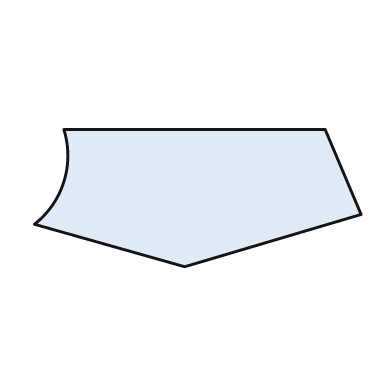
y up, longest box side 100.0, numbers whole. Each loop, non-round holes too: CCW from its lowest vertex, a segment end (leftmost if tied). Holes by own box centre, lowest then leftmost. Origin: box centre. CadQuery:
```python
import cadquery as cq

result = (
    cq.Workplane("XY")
    .moveTo(-4.0, -21.0)
    .lineTo(50.0, -5.0)
    .lineTo(39.0, 21.0)
    .lineTo(-41.0, 21.0)
    .threePointArc((-41.0, 5.0), (-50.0, -8.0))
    .close()
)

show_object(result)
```